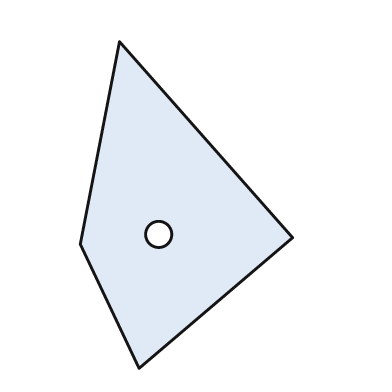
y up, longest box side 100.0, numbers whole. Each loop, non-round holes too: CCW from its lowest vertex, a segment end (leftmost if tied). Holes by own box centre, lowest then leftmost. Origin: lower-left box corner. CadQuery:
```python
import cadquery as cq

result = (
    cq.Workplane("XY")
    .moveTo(18.0, 0.0)
    .lineTo(65.0, 40.0)
    .lineTo(12.0, 100.0)
    .lineTo(0.0, 38.0)
    .close()
    .moveTo(24.0, 41.0)
    .circle(4.0)
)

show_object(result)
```